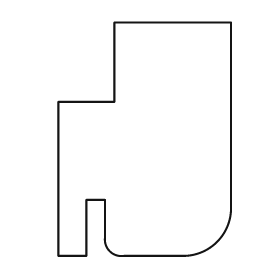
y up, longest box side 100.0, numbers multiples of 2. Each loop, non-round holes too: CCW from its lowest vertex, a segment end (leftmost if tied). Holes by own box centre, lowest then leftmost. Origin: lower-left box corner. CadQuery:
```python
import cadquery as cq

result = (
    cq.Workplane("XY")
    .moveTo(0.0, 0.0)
    .lineTo(12.0, 0.0)
    .lineTo(12.0, 24.0)
    .lineTo(20.0, 24.0)
    .lineTo(20.0, 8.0)
    .threePointArc((22.0, 2.0), (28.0, 0.0))
    .lineTo(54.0, 0.0)
    .threePointArc((68.0, 6.0), (74.0, 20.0))
    .lineTo(74.0, 100.0)
    .lineTo(24.0, 100.0)
    .lineTo(24.0, 66.0)
    .lineTo(0.0, 66.0)
    .close()
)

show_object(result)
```